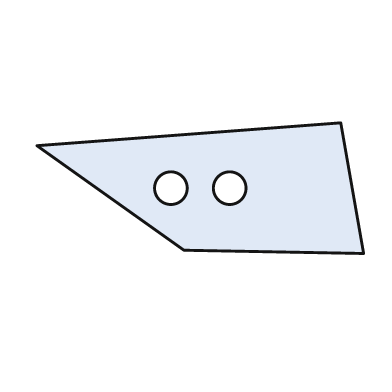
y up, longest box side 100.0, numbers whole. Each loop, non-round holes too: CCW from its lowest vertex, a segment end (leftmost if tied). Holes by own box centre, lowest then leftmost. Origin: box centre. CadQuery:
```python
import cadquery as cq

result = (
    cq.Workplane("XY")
    .moveTo(50.0, -20.0)
    .lineTo(43.0, 20.0)
    .lineTo(-50.0, 13.0)
    .lineTo(-5.0, -19.0)
    .close()
    .moveTo(-9.0, 0.0)
    .circle(5.0)
    .moveTo(9.0, 0.0)
    .circle(5.0)
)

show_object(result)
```